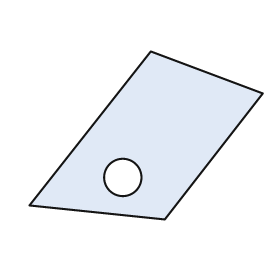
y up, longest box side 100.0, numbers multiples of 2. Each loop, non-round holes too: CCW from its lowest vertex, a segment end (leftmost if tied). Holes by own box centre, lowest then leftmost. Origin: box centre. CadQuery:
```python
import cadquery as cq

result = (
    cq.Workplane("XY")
    .moveTo(8.0, -36.0)
    .lineTo(50.0, 18.0)
    .lineTo(2.0, 36.0)
    .lineTo(-50.0, -30.0)
    .close()
    .moveTo(-10.0, -18.0)
    .circle(8.0)
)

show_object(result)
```